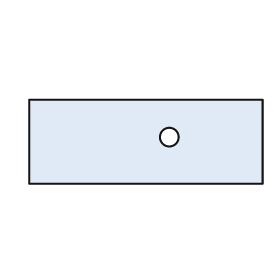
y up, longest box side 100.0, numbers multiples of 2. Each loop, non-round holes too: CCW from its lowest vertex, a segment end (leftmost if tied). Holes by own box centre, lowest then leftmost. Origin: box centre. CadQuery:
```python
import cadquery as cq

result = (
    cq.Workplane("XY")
    .moveTo(-50.0, -18.0)
    .lineTo(50.0, -18.0)
    .lineTo(50.0, 18.0)
    .lineTo(-50.0, 18.0)
    .close()
    .moveTo(10.0, 2.0)
    .circle(4.0)
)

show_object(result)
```